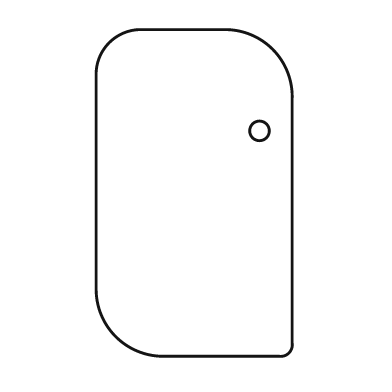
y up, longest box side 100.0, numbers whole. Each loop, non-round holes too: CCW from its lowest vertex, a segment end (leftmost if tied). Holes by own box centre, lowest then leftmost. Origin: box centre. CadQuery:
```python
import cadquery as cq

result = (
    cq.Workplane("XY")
    .moveTo(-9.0, -50.0)
    .lineTo(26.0, -50.0)
    .threePointArc((29.0, -49.0), (30.0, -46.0))
    .lineTo(30.0, 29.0)
    .threePointArc((24.0, 44.0), (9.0, 50.0))
    .lineTo(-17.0, 50.0)
    .threePointArc((-26.0, 46.0), (-30.0, 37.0))
    .lineTo(-30.0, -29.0)
    .threePointArc((-24.0, -44.0), (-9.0, -50.0))
    .close()
    .moveTo(20.0, 19.0)
    .circle(3.0)
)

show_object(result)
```